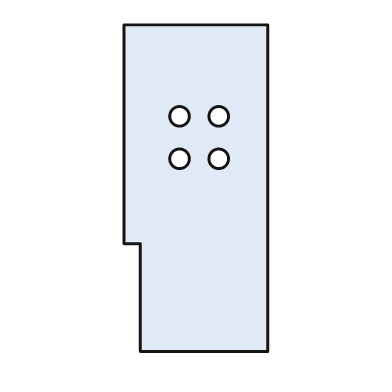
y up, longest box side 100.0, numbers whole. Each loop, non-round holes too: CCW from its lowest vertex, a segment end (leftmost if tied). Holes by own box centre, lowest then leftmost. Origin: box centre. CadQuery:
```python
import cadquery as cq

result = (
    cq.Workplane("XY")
    .moveTo(-17.0, -50.0)
    .lineTo(22.0, -50.0)
    .lineTo(22.0, 50.0)
    .lineTo(-22.0, 50.0)
    .lineTo(-22.0, -17.0)
    .lineTo(-17.0, -17.0)
    .close()
    .moveTo(-5.0, 9.0)
    .circle(3.0)
    .moveTo(7.0, 9.0)
    .circle(3.0)
    .moveTo(-5.0, 22.0)
    .circle(3.0)
    .moveTo(7.0, 22.0)
    .circle(3.0)
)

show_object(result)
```